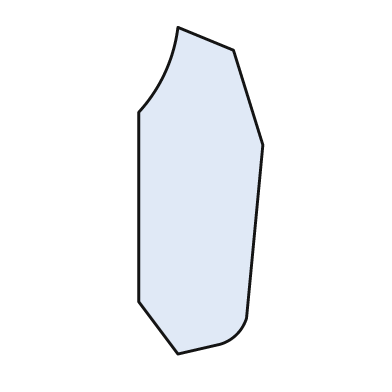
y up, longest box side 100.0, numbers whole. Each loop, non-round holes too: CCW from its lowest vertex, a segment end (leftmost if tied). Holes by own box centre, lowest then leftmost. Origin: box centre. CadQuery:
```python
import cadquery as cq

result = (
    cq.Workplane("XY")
    .moveTo(-7.0, -50.0)
    .lineTo(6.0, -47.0)
    .threePointArc((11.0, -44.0), (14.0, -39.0))
    .lineTo(19.0, 14.0)
    .lineTo(10.0, 43.0)
    .lineTo(-7.0, 50.0)
    .threePointArc((-11.0, 36.0), (-19.0, 24.0))
    .lineTo(-19.0, -34.0)
    .close()
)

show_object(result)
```